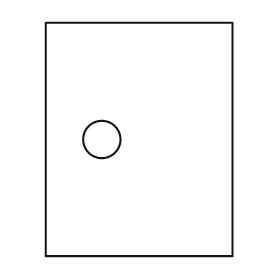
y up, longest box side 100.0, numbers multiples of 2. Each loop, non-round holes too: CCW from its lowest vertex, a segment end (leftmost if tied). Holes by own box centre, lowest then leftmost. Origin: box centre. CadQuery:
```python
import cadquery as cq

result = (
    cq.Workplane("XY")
    .moveTo(-40.0, -50.0)
    .lineTo(40.0, -50.0)
    .lineTo(40.0, 50.0)
    .lineTo(-40.0, 50.0)
    .close()
    .moveTo(-16.0, 0.0)
    .circle(8.0)
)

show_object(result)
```